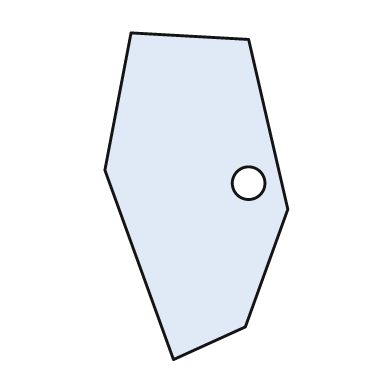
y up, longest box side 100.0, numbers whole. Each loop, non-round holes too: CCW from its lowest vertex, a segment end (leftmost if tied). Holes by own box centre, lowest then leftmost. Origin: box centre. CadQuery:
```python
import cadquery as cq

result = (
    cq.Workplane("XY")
    .moveTo(-7.0, -50.0)
    .lineTo(15.0, -40.0)
    .lineTo(28.0, -4.0)
    .lineTo(16.0, 48.0)
    .lineTo(-20.0, 50.0)
    .lineTo(-28.0, 8.0)
    .close()
    .moveTo(16.0, 4.0)
    .circle(5.0)
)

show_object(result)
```